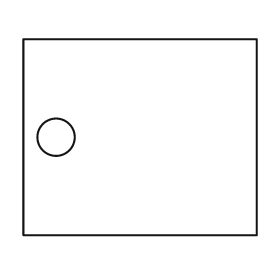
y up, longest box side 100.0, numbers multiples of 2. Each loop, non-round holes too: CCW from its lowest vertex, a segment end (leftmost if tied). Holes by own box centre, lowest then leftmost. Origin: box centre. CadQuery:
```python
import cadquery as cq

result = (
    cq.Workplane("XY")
    .moveTo(-50.0, -42.0)
    .lineTo(50.0, -42.0)
    .lineTo(50.0, 42.0)
    .lineTo(-50.0, 42.0)
    .close()
    .moveTo(-36.0, 0.0)
    .circle(8.0)
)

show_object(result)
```